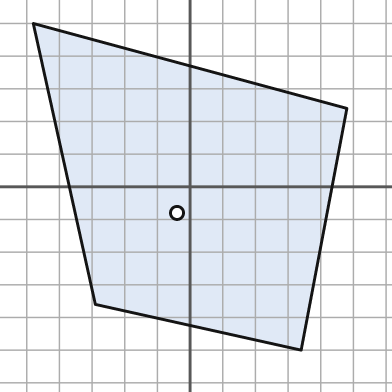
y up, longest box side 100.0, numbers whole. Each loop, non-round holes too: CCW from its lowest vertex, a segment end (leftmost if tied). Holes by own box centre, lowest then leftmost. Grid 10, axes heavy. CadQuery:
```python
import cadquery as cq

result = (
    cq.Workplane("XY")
    .moveTo(34.0, -50.0)
    .lineTo(48.0, 24.0)
    .lineTo(-48.0, 50.0)
    .lineTo(-29.0, -36.0)
    .close()
    .moveTo(-4.0, -8.0)
    .circle(2.0)
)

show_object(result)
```